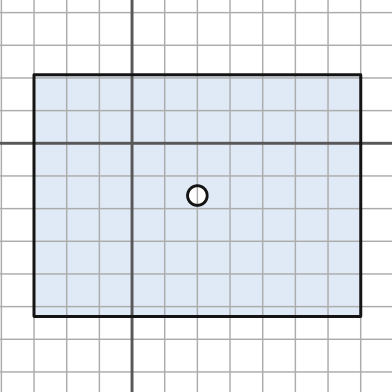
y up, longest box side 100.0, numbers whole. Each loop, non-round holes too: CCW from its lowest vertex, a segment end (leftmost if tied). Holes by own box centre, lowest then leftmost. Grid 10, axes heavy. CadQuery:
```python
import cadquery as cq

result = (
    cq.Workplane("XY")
    .moveTo(-30.0, -53.0)
    .lineTo(70.0, -53.0)
    .lineTo(70.0, 21.0)
    .lineTo(-30.0, 21.0)
    .close()
    .moveTo(20.0, -16.0)
    .circle(3.0)
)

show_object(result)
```